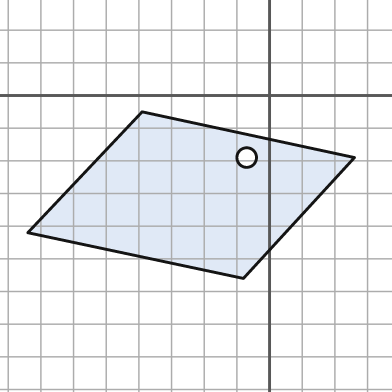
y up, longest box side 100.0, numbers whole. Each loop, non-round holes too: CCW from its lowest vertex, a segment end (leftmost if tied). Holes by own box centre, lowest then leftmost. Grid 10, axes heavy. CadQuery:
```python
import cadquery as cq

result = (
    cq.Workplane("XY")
    .moveTo(-8.0, -56.0)
    .lineTo(26.0, -19.0)
    .lineTo(-39.0, -5.0)
    .lineTo(-74.0, -42.0)
    .close()
    .moveTo(-7.0, -19.0)
    .circle(3.0)
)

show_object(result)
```